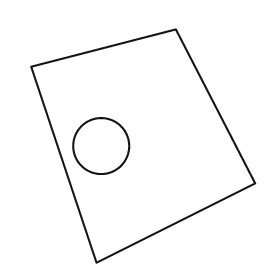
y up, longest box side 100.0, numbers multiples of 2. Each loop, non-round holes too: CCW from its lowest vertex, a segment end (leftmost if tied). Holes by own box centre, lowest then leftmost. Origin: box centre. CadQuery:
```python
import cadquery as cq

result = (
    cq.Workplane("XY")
    .moveTo(-20.0, -50.0)
    .lineTo(48.0, -16.0)
    .lineTo(14.0, 50.0)
    .lineTo(-48.0, 34.0)
    .close()
    .moveTo(-18.0, 0.0)
    .circle(12.0)
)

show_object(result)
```